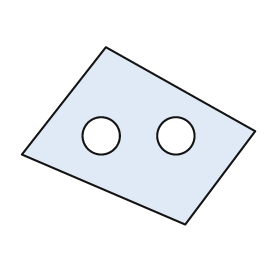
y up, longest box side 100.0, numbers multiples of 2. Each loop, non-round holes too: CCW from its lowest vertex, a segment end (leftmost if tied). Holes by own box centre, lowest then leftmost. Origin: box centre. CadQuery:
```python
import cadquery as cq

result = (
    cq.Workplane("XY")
    .moveTo(20.0, -38.0)
    .lineTo(50.0, 2.0)
    .lineTo(-14.0, 38.0)
    .lineTo(-50.0, -8.0)
    .close()
    .moveTo(-16.0, 0.0)
    .circle(8.0)
    .moveTo(16.0, 0.0)
    .circle(8.0)
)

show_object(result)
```